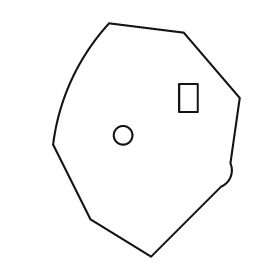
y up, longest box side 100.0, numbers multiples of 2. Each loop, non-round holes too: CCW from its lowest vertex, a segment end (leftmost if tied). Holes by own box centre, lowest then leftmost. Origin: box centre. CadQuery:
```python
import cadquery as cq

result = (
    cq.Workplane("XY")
    .moveTo(2.0, -50.0)
    .lineTo(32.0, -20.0)
    .threePointArc((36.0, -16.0), (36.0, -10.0))
    .lineTo(40.0, 18.0)
    .lineTo(16.0, 46.0)
    .lineTo(-16.0, 50.0)
    .threePointArc((-32.0, 26.0), (-40.0, -2.0))
    .lineTo(-24.0, -34.0)
    .close()
    .moveTo(-10.0, 2.0)
    .circle(4.0)
    .moveTo(14.0, 12.0)
    .lineTo(22.0, 12.0)
    .lineTo(22.0, 24.0)
    .lineTo(14.0, 24.0)
    .close()
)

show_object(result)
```